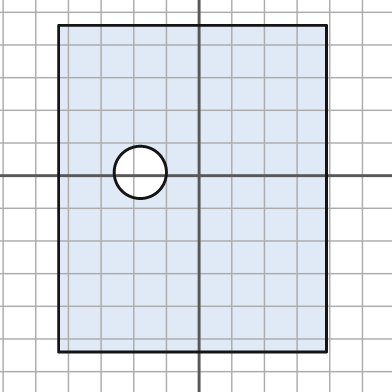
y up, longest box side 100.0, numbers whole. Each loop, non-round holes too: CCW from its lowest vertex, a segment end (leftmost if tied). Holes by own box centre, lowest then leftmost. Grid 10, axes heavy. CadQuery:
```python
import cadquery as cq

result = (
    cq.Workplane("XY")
    .moveTo(-43.0, -54.0)
    .lineTo(39.0, -54.0)
    .lineTo(39.0, 46.0)
    .lineTo(-43.0, 46.0)
    .close()
    .moveTo(-18.0, 1.0)
    .circle(8.0)
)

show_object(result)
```